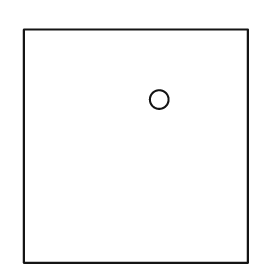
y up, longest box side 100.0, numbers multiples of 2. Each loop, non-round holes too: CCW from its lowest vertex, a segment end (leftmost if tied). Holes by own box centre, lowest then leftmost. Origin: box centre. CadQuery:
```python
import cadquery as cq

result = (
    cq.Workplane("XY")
    .moveTo(-48.0, -50.0)
    .lineTo(48.0, -50.0)
    .lineTo(48.0, 50.0)
    .lineTo(-48.0, 50.0)
    .close()
    .moveTo(10.0, 20.0)
    .circle(4.0)
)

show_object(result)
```